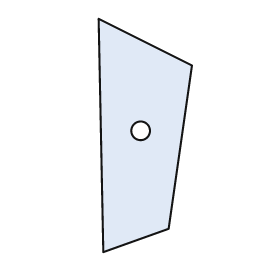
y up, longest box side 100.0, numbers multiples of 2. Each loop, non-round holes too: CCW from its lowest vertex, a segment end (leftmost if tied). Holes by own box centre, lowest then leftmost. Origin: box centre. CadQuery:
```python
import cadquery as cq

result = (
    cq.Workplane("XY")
    .moveTo(-18.0, -50.0)
    .lineTo(10.0, -40.0)
    .lineTo(20.0, 30.0)
    .lineTo(-20.0, 50.0)
    .close()
    .moveTo(-2.0, 2.0)
    .circle(4.0)
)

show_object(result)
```